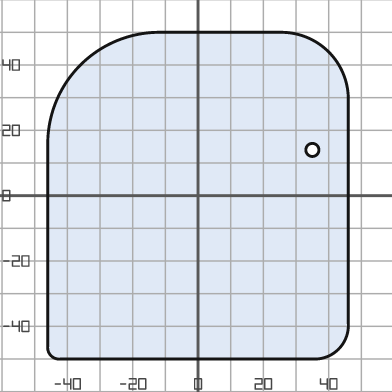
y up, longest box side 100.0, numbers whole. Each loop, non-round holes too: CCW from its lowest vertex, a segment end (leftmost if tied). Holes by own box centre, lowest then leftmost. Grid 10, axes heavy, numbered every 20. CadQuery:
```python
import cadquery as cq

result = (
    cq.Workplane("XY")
    .moveTo(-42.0, -50.0)
    .lineTo(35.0, -50.0)
    .threePointArc((43.0, -47.0), (46.0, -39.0))
    .lineTo(46.0, 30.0)
    .threePointArc((40.0, 44.0), (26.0, 50.0))
    .lineTo(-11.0, 50.0)
    .threePointArc((-36.0, 40.0), (-46.0, 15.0))
    .lineTo(-46.0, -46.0)
    .threePointArc((-45.0, -49.0), (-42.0, -50.0))
    .close()
    .moveTo(35.0, 14.0)
    .circle(2.0)
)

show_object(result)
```